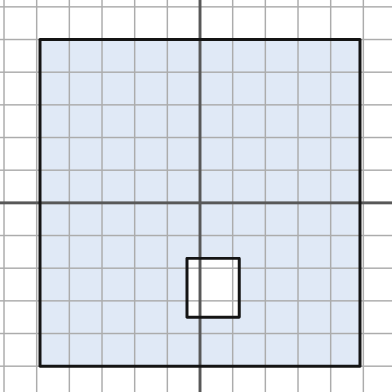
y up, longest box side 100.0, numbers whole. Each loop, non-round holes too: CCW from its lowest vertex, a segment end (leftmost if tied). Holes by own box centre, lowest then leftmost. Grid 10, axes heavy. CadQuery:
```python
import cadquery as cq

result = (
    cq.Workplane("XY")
    .moveTo(-49.0, -50.0)
    .lineTo(49.0, -50.0)
    .lineTo(49.0, 50.0)
    .lineTo(-49.0, 50.0)
    .close()
    .moveTo(-4.0, -35.0)
    .lineTo(12.0, -35.0)
    .lineTo(12.0, -17.0)
    .lineTo(-4.0, -17.0)
    .close()
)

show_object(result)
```